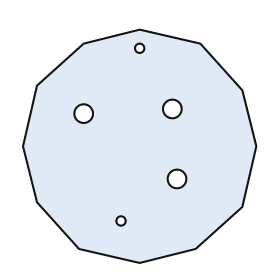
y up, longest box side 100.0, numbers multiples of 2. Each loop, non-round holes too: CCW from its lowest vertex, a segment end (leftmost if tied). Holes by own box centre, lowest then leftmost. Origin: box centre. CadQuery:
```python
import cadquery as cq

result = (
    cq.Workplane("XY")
    .moveTo(0.0, -50.0)
    .lineTo(24.0, -44.0)
    .lineTo(44.0, -26.0)
    .lineTo(50.0, 0.0)
    .lineTo(44.0, 24.0)
    .lineTo(26.0, 44.0)
    .lineTo(0.0, 50.0)
    .lineTo(-24.0, 44.0)
    .lineTo(-44.0, 26.0)
    .lineTo(-50.0, 0.0)
    .lineTo(-44.0, -24.0)
    .lineTo(-26.0, -44.0)
    .close()
    .moveTo(-8.0, -32.0)
    .circle(2.0)
    .moveTo(16.0, -14.0)
    .circle(4.0)
    .moveTo(-24.0, 14.0)
    .circle(4.0)
    .moveTo(14.0, 16.0)
    .circle(4.0)
    .moveTo(0.0, 42.0)
    .circle(2.0)
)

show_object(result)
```